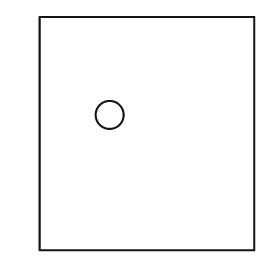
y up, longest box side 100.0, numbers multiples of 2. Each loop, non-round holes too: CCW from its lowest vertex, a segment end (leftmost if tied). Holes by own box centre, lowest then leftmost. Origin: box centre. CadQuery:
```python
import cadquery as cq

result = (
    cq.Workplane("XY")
    .moveTo(-46.0, -50.0)
    .lineTo(46.0, -50.0)
    .lineTo(46.0, 50.0)
    .lineTo(-46.0, 50.0)
    .close()
    .moveTo(-16.0, 8.0)
    .circle(6.0)
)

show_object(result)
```